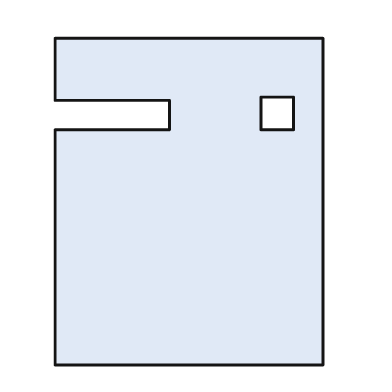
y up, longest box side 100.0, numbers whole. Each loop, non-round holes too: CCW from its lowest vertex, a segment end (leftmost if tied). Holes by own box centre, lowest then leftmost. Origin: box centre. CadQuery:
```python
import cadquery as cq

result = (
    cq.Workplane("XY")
    .moveTo(-41.0, -50.0)
    .lineTo(41.0, -50.0)
    .lineTo(41.0, 50.0)
    .lineTo(-41.0, 50.0)
    .lineTo(-41.0, 31.0)
    .lineTo(-6.0, 31.0)
    .lineTo(-6.0, 22.0)
    .lineTo(-41.0, 22.0)
    .close()
    .moveTo(22.0, 22.0)
    .lineTo(32.0, 22.0)
    .lineTo(32.0, 32.0)
    .lineTo(22.0, 32.0)
    .close()
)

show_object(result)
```